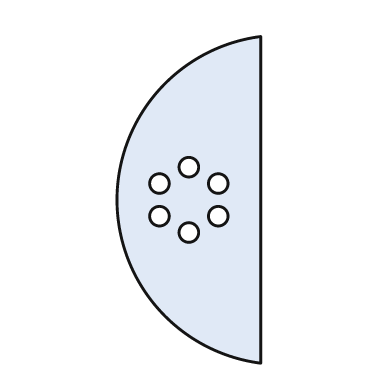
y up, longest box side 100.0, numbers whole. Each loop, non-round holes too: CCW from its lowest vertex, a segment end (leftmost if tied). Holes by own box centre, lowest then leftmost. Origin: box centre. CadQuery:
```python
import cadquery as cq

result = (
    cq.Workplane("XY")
    .moveTo(22.0, -50.0)
    .lineTo(22.0, 50.0)
    .threePointArc((-22.0, 0.0), (22.0, -50.0))
    .close()
    .moveTo(0.0, -10.0)
    .circle(3.0)
    .moveTo(-9.0, -5.0)
    .circle(3.0)
    .moveTo(9.0, -5.0)
    .circle(3.0)
    .moveTo(-9.0, 5.0)
    .circle(3.0)
    .moveTo(9.0, 5.0)
    .circle(3.0)
    .moveTo(0.0, 10.0)
    .circle(3.0)
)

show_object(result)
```